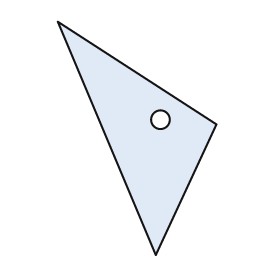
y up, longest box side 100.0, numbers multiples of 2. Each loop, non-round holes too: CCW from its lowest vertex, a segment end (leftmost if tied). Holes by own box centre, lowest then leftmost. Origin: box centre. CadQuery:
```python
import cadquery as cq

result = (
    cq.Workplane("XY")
    .moveTo(8.0, -50.0)
    .lineTo(34.0, 6.0)
    .lineTo(-34.0, 50.0)
    .close()
    .moveTo(10.0, 8.0)
    .circle(4.0)
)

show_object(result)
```